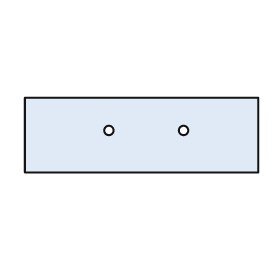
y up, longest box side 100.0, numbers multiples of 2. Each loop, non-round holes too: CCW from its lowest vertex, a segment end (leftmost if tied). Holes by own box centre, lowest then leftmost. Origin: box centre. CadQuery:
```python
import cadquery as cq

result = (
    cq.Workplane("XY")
    .moveTo(-50.0, -16.0)
    .lineTo(50.0, -16.0)
    .lineTo(50.0, 16.0)
    .lineTo(-50.0, 16.0)
    .close()
    .moveTo(-14.0, 2.0)
    .circle(2.0)
    .moveTo(18.0, 2.0)
    .circle(2.0)
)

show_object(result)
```